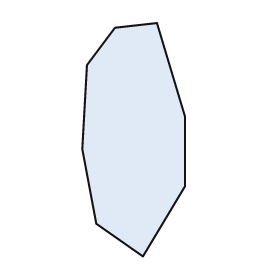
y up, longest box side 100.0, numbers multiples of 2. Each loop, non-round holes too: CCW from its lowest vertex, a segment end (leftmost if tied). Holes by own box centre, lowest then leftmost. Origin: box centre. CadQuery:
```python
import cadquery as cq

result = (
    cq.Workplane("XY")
    .moveTo(4.0, -50.0)
    .lineTo(22.0, -20.0)
    .lineTo(22.0, 10.0)
    .lineTo(10.0, 50.0)
    .lineTo(-8.0, 48.0)
    .lineTo(-20.0, 32.0)
    .lineTo(-22.0, -4.0)
    .lineTo(-16.0, -36.0)
    .close()
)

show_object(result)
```